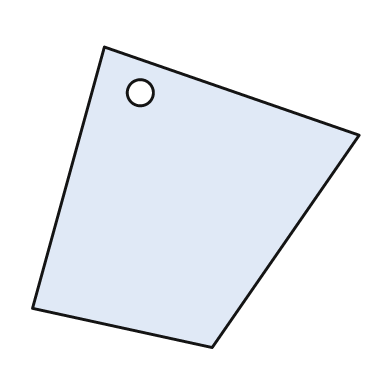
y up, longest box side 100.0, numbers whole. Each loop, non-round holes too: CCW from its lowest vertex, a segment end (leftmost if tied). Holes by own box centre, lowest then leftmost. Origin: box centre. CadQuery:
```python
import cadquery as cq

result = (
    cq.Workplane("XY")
    .moveTo(5.0, -46.0)
    .lineTo(50.0, 19.0)
    .lineTo(-28.0, 46.0)
    .lineTo(-50.0, -34.0)
    .close()
    .moveTo(-17.0, 32.0)
    .circle(4.0)
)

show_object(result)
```